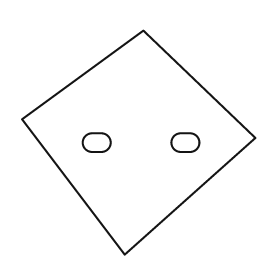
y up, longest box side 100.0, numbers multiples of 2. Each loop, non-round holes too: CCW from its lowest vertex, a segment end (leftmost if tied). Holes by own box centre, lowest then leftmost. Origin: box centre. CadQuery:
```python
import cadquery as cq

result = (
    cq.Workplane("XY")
    .moveTo(-6.0, -48.0)
    .lineTo(50.0, 2.0)
    .lineTo(2.0, 48.0)
    .lineTo(-50.0, 10.0)
    .close()
    .moveTo(-20.0, -4.0)
    .lineTo(-16.0, -4.0)
    .threePointArc((-12.0, 0.0), (-16.0, 4.0))
    .lineTo(-20.0, 4.0)
    .threePointArc((-24.0, 0.0), (-20.0, -4.0))
    .close()
    .moveTo(18.0, -4.0)
    .lineTo(22.0, -4.0)
    .threePointArc((26.0, 0.0), (22.0, 4.0))
    .lineTo(18.0, 4.0)
    .threePointArc((14.0, 0.0), (18.0, -4.0))
    .close()
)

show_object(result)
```